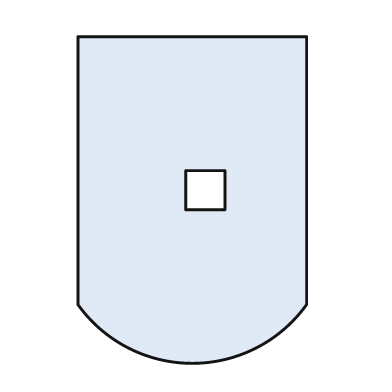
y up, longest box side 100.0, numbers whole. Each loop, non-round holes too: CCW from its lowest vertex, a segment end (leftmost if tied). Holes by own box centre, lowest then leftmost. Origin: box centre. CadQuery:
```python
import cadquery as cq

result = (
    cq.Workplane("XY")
    .moveTo(-35.0, -32.0)
    .threePointArc((0.0, -50.0), (35.0, -32.0))
    .lineTo(35.0, 50.0)
    .lineTo(-35.0, 50.0)
    .close()
    .moveTo(-2.0, -3.0)
    .lineTo(10.0, -3.0)
    .lineTo(10.0, 9.0)
    .lineTo(-2.0, 9.0)
    .close()
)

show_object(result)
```